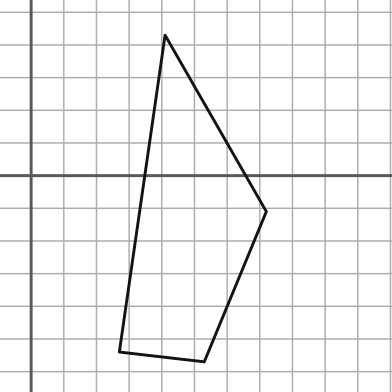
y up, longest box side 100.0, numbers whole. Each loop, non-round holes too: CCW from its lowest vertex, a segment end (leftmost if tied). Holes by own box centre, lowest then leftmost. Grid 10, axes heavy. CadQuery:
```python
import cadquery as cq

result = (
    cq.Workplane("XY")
    .moveTo(53.0, -57.0)
    .lineTo(72.0, -11.0)
    .lineTo(41.0, 43.0)
    .lineTo(27.0, -54.0)
    .close()
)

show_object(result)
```